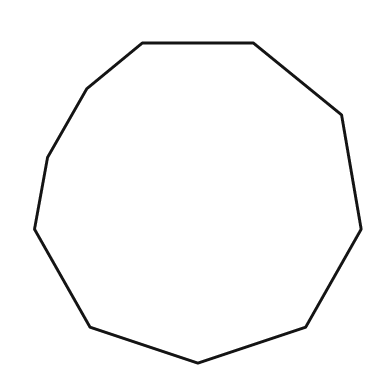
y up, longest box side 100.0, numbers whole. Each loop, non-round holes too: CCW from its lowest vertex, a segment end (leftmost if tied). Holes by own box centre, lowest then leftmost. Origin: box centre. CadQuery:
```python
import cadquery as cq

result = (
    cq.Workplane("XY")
    .moveTo(0.0, -49.0)
    .lineTo(33.0, -38.0)
    .lineTo(50.0, -8.0)
    .lineTo(44.0, 27.0)
    .lineTo(17.0, 49.0)
    .lineTo(-17.0, 49.0)
    .lineTo(-34.0, 35.0)
    .lineTo(-46.0, 14.0)
    .lineTo(-50.0, -8.0)
    .lineTo(-33.0, -38.0)
    .close()
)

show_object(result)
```